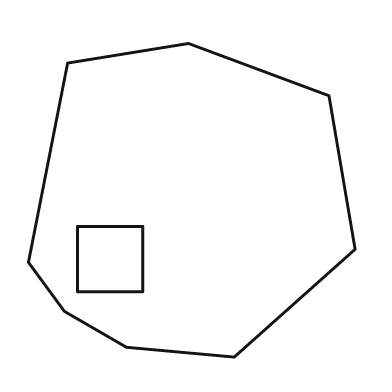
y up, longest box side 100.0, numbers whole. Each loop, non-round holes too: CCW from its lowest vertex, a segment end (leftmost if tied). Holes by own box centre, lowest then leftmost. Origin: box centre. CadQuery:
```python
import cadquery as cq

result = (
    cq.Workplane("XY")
    .moveTo(13.0, -48.0)
    .lineTo(50.0, -15.0)
    .lineTo(42.0, 32.0)
    .lineTo(-1.0, 48.0)
    .lineTo(-38.0, 42.0)
    .lineTo(-50.0, -19.0)
    .lineTo(-39.0, -34.0)
    .lineTo(-20.0, -45.0)
    .close()
    .moveTo(-35.0, -28.0)
    .lineTo(-15.0, -28.0)
    .lineTo(-15.0, -8.0)
    .lineTo(-35.0, -8.0)
    .close()
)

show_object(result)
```